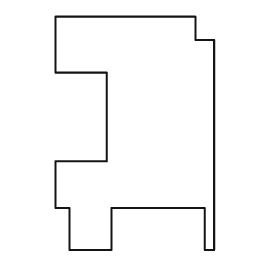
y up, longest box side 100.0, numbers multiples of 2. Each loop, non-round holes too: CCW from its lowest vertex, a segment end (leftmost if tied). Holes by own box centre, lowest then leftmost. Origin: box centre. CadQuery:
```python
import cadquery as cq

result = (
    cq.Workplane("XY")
    .moveTo(-28.0, -50.0)
    .lineTo(-10.0, -50.0)
    .lineTo(-10.0, -32.0)
    .lineTo(30.0, -32.0)
    .lineTo(30.0, -50.0)
    .lineTo(34.0, -50.0)
    .lineTo(34.0, 40.0)
    .lineTo(26.0, 40.0)
    .lineTo(26.0, 50.0)
    .lineTo(-34.0, 50.0)
    .lineTo(-34.0, 26.0)
    .lineTo(-12.0, 26.0)
    .lineTo(-12.0, -12.0)
    .lineTo(-34.0, -12.0)
    .lineTo(-34.0, -32.0)
    .lineTo(-28.0, -32.0)
    .close()
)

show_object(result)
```